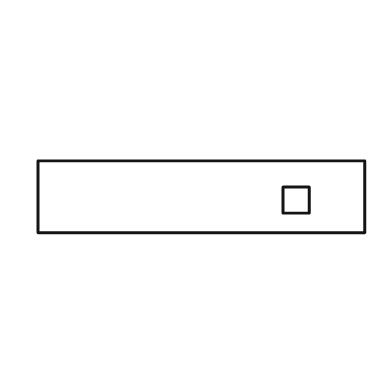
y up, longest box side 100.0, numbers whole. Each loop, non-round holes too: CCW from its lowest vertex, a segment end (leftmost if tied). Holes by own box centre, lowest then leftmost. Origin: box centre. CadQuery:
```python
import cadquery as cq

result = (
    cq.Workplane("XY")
    .moveTo(-50.0, -11.0)
    .lineTo(50.0, -11.0)
    .lineTo(50.0, 11.0)
    .lineTo(-50.0, 11.0)
    .close()
    .moveTo(25.0, -5.0)
    .lineTo(33.0, -5.0)
    .lineTo(33.0, 3.0)
    .lineTo(25.0, 3.0)
    .close()
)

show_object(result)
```